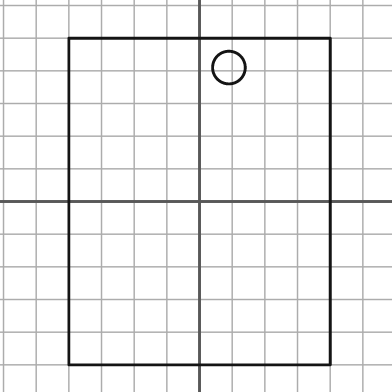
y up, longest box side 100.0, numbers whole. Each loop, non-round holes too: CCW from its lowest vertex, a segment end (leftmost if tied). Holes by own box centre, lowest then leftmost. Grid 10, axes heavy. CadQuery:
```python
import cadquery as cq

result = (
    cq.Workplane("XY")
    .moveTo(-40.0, -50.0)
    .lineTo(40.0, -50.0)
    .lineTo(40.0, 50.0)
    .lineTo(-40.0, 50.0)
    .close()
    .moveTo(9.0, 41.0)
    .circle(5.0)
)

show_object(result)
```